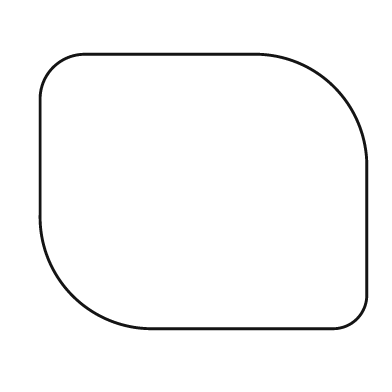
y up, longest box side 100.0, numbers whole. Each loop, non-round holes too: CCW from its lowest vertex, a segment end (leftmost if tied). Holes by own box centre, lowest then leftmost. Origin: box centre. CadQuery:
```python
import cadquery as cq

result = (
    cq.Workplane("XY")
    .moveTo(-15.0, -42.0)
    .lineTo(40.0, -42.0)
    .threePointArc((47.0, -39.0), (50.0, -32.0))
    .lineTo(50.0, 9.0)
    .threePointArc((40.0, 32.0), (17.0, 42.0))
    .lineTo(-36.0, 42.0)
    .threePointArc((-46.0, 38.0), (-50.0, 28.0))
    .lineTo(-50.0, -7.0)
    .threePointArc((-40.0, -32.0), (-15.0, -42.0))
    .close()
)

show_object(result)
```